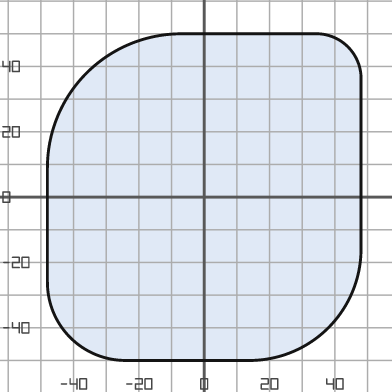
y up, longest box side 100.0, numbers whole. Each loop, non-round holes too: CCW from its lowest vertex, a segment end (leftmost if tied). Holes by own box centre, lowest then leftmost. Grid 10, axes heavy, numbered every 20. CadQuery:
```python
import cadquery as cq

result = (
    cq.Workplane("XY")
    .moveTo(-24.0, -50.0)
    .lineTo(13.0, -50.0)
    .threePointArc((38.0, -40.0), (48.0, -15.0))
    .lineTo(48.0, 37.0)
    .threePointArc((44.0, 46.0), (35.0, 50.0))
    .lineTo(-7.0, 50.0)
    .threePointArc((-36.0, 38.0), (-48.0, 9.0))
    .lineTo(-48.0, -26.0)
    .threePointArc((-41.0, -43.0), (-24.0, -50.0))
    .close()
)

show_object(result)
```